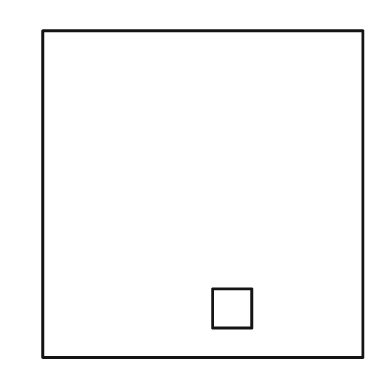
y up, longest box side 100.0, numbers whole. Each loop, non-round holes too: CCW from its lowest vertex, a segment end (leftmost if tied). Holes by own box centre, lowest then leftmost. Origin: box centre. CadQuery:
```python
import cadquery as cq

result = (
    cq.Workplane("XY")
    .moveTo(-49.0, -50.0)
    .lineTo(49.0, -50.0)
    .lineTo(49.0, 50.0)
    .lineTo(-49.0, 50.0)
    .close()
    .moveTo(3.0, -41.0)
    .lineTo(15.0, -41.0)
    .lineTo(15.0, -29.0)
    .lineTo(3.0, -29.0)
    .close()
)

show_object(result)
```